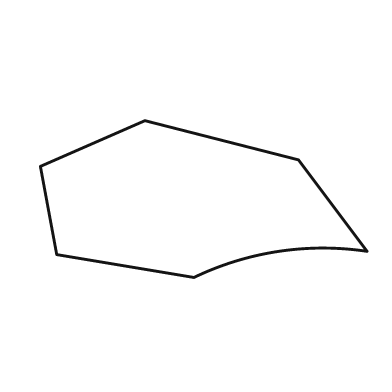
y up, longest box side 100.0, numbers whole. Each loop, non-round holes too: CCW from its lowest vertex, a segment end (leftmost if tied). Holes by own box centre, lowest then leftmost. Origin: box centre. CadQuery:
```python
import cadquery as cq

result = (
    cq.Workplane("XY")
    .moveTo(-3.0, -24.0)
    .threePointArc((23.0, -16.0), (50.0, -16.0))
    .lineTo(29.0, 12.0)
    .lineTo(-18.0, 24.0)
    .lineTo(-50.0, 10.0)
    .lineTo(-45.0, -17.0)
    .close()
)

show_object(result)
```